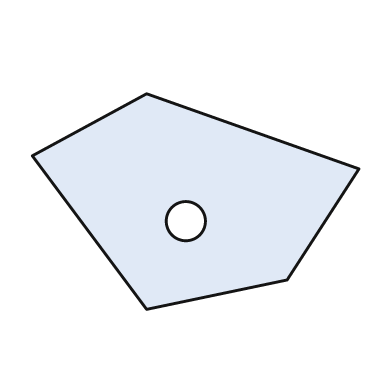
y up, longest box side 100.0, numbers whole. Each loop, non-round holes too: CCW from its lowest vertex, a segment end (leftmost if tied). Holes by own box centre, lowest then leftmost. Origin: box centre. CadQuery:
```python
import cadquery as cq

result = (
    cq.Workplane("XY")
    .moveTo(-15.0, -33.0)
    .lineTo(28.0, -24.0)
    .lineTo(50.0, 10.0)
    .lineTo(-15.0, 33.0)
    .lineTo(-50.0, 14.0)
    .close()
    .moveTo(-3.0, -6.0)
    .circle(6.0)
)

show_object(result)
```